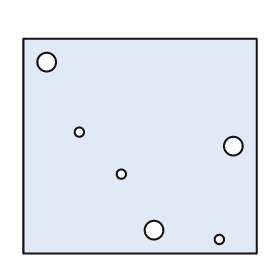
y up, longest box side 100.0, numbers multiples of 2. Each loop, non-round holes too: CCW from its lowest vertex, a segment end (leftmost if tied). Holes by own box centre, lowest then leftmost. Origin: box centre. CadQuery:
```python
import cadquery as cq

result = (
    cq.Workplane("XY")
    .moveTo(-50.0, -46.0)
    .lineTo(50.0, -46.0)
    .lineTo(50.0, 46.0)
    .lineTo(-50.0, 46.0)
    .close()
    .moveTo(34.0, -40.0)
    .circle(2.0)
    .moveTo(6.0, -36.0)
    .circle(4.0)
    .moveTo(-8.0, -12.0)
    .circle(2.0)
    .moveTo(40.0, 0.0)
    .circle(4.0)
    .moveTo(-26.0, 6.0)
    .circle(2.0)
    .moveTo(-40.0, 36.0)
    .circle(4.0)
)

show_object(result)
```